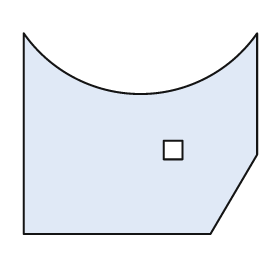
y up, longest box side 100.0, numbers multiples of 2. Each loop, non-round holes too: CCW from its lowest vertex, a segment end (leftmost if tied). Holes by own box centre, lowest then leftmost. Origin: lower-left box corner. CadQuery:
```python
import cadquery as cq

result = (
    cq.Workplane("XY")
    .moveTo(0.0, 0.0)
    .lineTo(80.0, 0.0)
    .lineTo(100.0, 34.0)
    .lineTo(100.0, 86.0)
    .threePointArc((50.0, 60.0), (0.0, 86.0))
    .close()
    .moveTo(60.0, 32.0)
    .lineTo(68.0, 32.0)
    .lineTo(68.0, 40.0)
    .lineTo(60.0, 40.0)
    .close()
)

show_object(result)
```